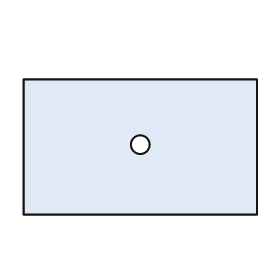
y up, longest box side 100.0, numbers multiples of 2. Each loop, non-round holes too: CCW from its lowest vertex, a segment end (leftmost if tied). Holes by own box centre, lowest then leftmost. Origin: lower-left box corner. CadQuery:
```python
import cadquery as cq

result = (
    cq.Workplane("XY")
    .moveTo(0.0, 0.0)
    .lineTo(100.0, 0.0)
    .lineTo(100.0, 58.0)
    .lineTo(0.0, 58.0)
    .close()
    .moveTo(50.0, 30.0)
    .circle(4.0)
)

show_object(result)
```